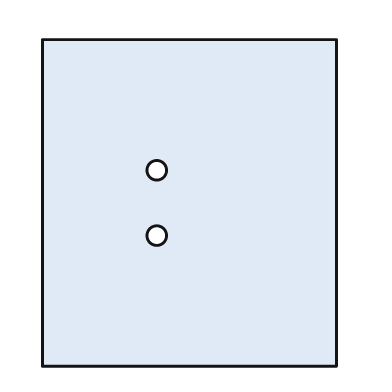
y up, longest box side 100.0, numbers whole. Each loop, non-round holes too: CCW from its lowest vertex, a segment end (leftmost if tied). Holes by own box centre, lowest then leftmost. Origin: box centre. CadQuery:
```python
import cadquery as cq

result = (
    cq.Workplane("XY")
    .moveTo(-45.0, -50.0)
    .lineTo(45.0, -50.0)
    .lineTo(45.0, 50.0)
    .lineTo(-45.0, 50.0)
    .close()
    .moveTo(-10.0, -10.0)
    .circle(3.0)
    .moveTo(-10.0, 10.0)
    .circle(3.0)
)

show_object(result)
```